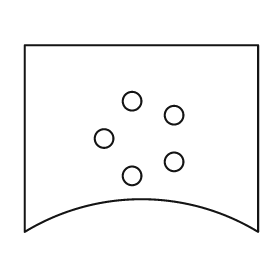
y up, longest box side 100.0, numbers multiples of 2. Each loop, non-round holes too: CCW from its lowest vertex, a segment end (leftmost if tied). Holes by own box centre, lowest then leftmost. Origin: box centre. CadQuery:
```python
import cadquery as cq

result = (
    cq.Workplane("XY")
    .moveTo(-50.0, -40.0)
    .threePointArc((0.0, -26.0), (50.0, -40.0))
    .lineTo(50.0, 40.0)
    .lineTo(-50.0, 40.0)
    .close()
    .moveTo(-4.0, -16.0)
    .circle(4.0)
    .moveTo(14.0, -10.0)
    .circle(4.0)
    .moveTo(-16.0, 0.0)
    .circle(4.0)
    .moveTo(14.0, 10.0)
    .circle(4.0)
    .moveTo(-4.0, 16.0)
    .circle(4.0)
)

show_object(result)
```